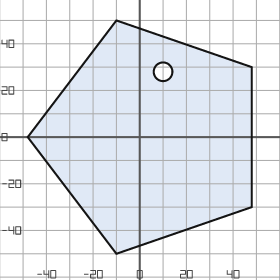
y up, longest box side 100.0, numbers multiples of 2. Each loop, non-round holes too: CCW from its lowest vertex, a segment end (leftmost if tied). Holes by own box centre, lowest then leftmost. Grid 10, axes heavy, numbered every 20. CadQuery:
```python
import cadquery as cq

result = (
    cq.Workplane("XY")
    .moveTo(-10.0, -50.0)
    .lineTo(48.0, -30.0)
    .lineTo(48.0, 30.0)
    .lineTo(-10.0, 50.0)
    .lineTo(-48.0, 0.0)
    .close()
    .moveTo(10.0, 28.0)
    .circle(4.0)
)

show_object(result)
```